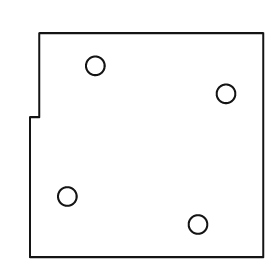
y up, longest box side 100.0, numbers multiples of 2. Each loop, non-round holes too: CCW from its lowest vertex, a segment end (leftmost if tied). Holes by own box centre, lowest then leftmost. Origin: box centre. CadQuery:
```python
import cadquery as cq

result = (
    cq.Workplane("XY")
    .moveTo(-50.0, -48.0)
    .lineTo(50.0, -48.0)
    .lineTo(50.0, 48.0)
    .lineTo(-46.0, 48.0)
    .lineTo(-46.0, 12.0)
    .lineTo(-50.0, 12.0)
    .close()
    .moveTo(22.0, -34.0)
    .circle(4.0)
    .moveTo(-34.0, -22.0)
    .circle(4.0)
    .moveTo(34.0, 22.0)
    .circle(4.0)
    .moveTo(-22.0, 34.0)
    .circle(4.0)
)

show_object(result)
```